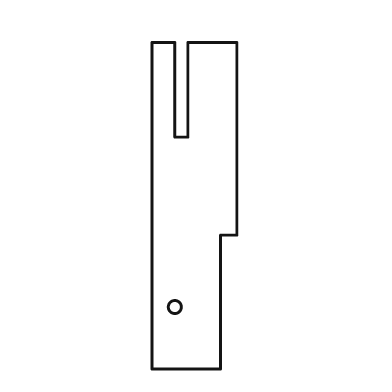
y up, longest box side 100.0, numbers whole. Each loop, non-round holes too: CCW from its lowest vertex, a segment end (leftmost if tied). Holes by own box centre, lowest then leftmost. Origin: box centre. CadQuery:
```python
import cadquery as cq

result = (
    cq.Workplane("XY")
    .moveTo(-13.0, -50.0)
    .lineTo(8.0, -50.0)
    .lineTo(8.0, -9.0)
    .lineTo(13.0, -9.0)
    .lineTo(13.0, 50.0)
    .lineTo(-2.0, 50.0)
    .lineTo(-2.0, 21.0)
    .lineTo(-6.0, 21.0)
    .lineTo(-6.0, 50.0)
    .lineTo(-13.0, 50.0)
    .close()
    .moveTo(-6.0, -31.0)
    .circle(2.0)
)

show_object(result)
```